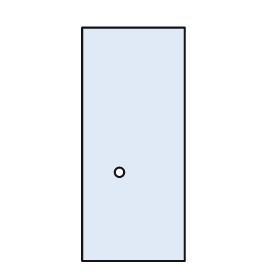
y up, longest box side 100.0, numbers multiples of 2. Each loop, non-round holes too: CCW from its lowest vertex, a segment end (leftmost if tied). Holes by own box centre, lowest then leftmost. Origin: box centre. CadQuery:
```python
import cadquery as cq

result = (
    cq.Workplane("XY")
    .moveTo(-22.0, -50.0)
    .lineTo(22.0, -50.0)
    .lineTo(22.0, 50.0)
    .lineTo(-22.0, 50.0)
    .close()
    .moveTo(-6.0, -12.0)
    .circle(2.0)
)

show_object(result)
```